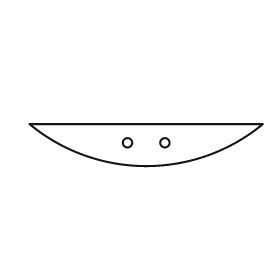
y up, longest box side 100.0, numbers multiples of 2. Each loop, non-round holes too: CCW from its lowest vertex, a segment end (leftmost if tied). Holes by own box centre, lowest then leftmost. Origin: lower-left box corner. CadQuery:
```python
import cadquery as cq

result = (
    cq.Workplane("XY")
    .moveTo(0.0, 18.0)
    .threePointArc((50.0, 0.0), (100.0, 18.0))
    .close()
    .moveTo(42.0, 10.0)
    .circle(2.0)
    .moveTo(58.0, 10.0)
    .circle(2.0)
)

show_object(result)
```